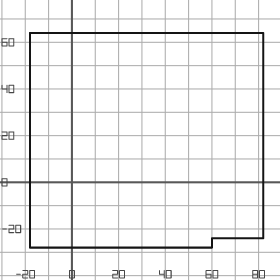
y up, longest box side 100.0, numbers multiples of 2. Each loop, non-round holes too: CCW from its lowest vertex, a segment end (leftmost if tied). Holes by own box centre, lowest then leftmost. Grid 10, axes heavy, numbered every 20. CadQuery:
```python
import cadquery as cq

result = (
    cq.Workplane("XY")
    .moveTo(-18.0, -28.0)
    .lineTo(60.0, -28.0)
    .lineTo(60.0, -24.0)
    .lineTo(82.0, -24.0)
    .lineTo(82.0, 64.0)
    .lineTo(-18.0, 64.0)
    .close()
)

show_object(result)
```